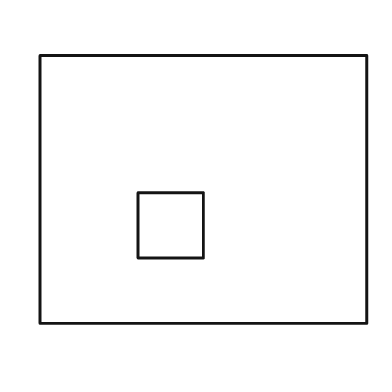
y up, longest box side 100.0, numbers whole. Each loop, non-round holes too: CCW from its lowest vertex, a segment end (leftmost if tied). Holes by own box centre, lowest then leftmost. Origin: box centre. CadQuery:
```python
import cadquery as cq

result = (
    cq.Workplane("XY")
    .moveTo(-50.0, -41.0)
    .lineTo(50.0, -41.0)
    .lineTo(50.0, 41.0)
    .lineTo(-50.0, 41.0)
    .close()
    .moveTo(-20.0, -21.0)
    .lineTo(0.0, -21.0)
    .lineTo(0.0, -1.0)
    .lineTo(-20.0, -1.0)
    .close()
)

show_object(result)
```